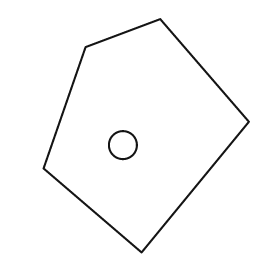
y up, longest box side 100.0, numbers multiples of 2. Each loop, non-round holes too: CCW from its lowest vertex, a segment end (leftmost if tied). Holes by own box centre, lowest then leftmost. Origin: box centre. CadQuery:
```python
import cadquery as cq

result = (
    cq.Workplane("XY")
    .moveTo(-2.0, -50.0)
    .lineTo(44.0, 6.0)
    .lineTo(6.0, 50.0)
    .lineTo(-26.0, 38.0)
    .lineTo(-44.0, -14.0)
    .close()
    .moveTo(-10.0, -4.0)
    .circle(6.0)
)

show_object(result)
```